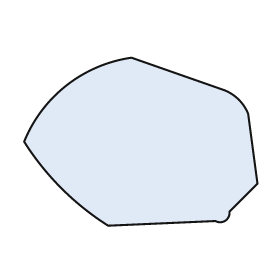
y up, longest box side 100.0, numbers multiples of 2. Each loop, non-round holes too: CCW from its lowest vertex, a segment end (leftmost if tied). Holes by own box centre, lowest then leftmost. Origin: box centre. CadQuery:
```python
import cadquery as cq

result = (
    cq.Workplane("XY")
    .moveTo(-14.0, -36.0)
    .lineTo(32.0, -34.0)
    .threePointArc((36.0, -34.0), (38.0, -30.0))
    .lineTo(50.0, -18.0)
    .lineTo(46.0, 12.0)
    .threePointArc((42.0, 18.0), (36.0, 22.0))
    .lineTo(-4.0, 36.0)
    .threePointArc((-32.0, 24.0), (-50.0, 0.0))
    .threePointArc((-34.0, -20.0), (-14.0, -36.0))
    .close()
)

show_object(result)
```